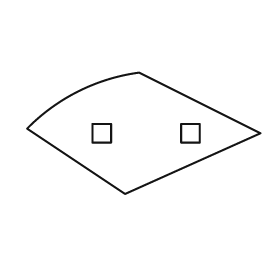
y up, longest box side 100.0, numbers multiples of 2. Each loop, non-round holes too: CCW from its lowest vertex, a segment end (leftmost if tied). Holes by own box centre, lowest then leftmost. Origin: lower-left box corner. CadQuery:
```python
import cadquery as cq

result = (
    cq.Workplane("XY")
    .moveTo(42.0, 0.0)
    .lineTo(100.0, 26.0)
    .lineTo(48.0, 52.0)
    .threePointArc((22.0, 44.0), (0.0, 28.0))
    .close()
    .moveTo(28.0, 22.0)
    .lineTo(36.0, 22.0)
    .lineTo(36.0, 30.0)
    .lineTo(28.0, 30.0)
    .close()
    .moveTo(66.0, 22.0)
    .lineTo(74.0, 22.0)
    .lineTo(74.0, 30.0)
    .lineTo(66.0, 30.0)
    .close()
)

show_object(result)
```